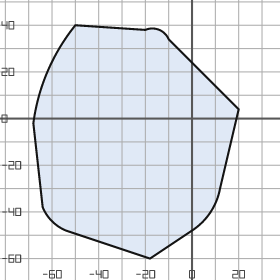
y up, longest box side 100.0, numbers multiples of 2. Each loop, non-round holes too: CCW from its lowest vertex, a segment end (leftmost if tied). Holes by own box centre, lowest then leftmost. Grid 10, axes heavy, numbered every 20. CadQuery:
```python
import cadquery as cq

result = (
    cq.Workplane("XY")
    .moveTo(-18.0, -60.0)
    .lineTo(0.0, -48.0)
    .threePointArc((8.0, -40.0), (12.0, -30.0))
    .lineTo(20.0, 4.0)
    .lineTo(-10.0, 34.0)
    .threePointArc((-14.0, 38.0), (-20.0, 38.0))
    .lineTo(-50.0, 40.0)
    .threePointArc((-62.0, 20.0), (-68.0, -2.0))
    .lineTo(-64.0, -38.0)
    .threePointArc((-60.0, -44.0), (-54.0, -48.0))
    .close()
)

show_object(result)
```